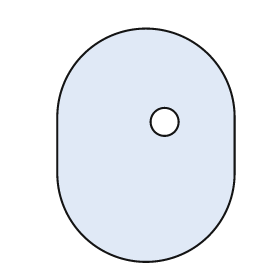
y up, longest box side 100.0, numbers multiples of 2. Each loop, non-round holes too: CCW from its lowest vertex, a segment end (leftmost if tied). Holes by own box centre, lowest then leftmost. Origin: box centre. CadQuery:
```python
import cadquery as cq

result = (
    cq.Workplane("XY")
    .moveTo(-38.0, -12.0)
    .threePointArc((0.0, -50.0), (38.0, -12.0))
    .lineTo(38.0, 12.0)
    .threePointArc((0.0, 50.0), (-38.0, 12.0))
    .close()
    .moveTo(8.0, 10.0)
    .circle(6.0)
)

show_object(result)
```